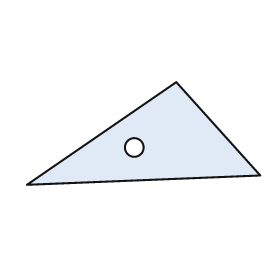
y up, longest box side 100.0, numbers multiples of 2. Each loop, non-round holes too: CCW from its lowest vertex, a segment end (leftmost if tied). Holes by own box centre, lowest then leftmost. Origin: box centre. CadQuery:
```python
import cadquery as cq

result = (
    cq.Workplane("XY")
    .moveTo(-50.0, -22.0)
    .lineTo(50.0, -18.0)
    .lineTo(14.0, 22.0)
    .close()
    .moveTo(-4.0, -6.0)
    .circle(4.0)
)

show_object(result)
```